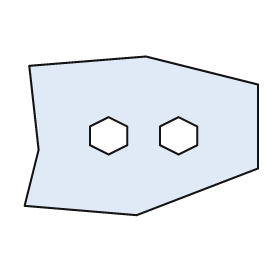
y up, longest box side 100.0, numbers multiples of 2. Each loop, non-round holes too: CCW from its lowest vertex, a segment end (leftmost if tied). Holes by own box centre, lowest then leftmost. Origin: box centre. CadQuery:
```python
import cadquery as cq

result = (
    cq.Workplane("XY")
    .moveTo(-2.0, -34.0)
    .lineTo(50.0, -14.0)
    .lineTo(50.0, 22.0)
    .lineTo(2.0, 34.0)
    .lineTo(-48.0, 30.0)
    .lineTo(-44.0, -6.0)
    .lineTo(-50.0, -30.0)
    .close()
    .moveTo(-14.0, -8.0)
    .lineTo(-6.0, -4.0)
    .lineTo(-6.0, 4.0)
    .lineTo(-14.0, 8.0)
    .lineTo(-22.0, 4.0)
    .lineTo(-22.0, -4.0)
    .close()
    .moveTo(16.0, -8.0)
    .lineTo(24.0, -4.0)
    .lineTo(24.0, 4.0)
    .lineTo(16.0, 8.0)
    .lineTo(8.0, 4.0)
    .lineTo(8.0, -4.0)
    .close()
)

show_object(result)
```